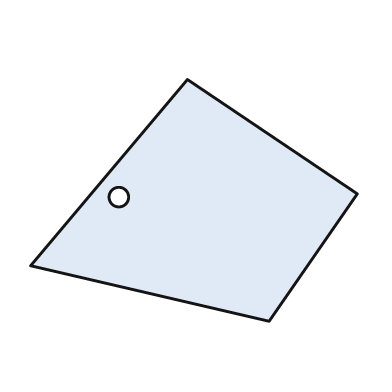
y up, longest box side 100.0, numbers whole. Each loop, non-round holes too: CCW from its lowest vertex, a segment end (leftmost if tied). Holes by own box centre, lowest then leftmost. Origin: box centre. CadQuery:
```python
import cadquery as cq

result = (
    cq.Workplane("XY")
    .moveTo(23.0, -37.0)
    .lineTo(50.0, 2.0)
    .lineTo(-2.0, 37.0)
    .lineTo(-50.0, -20.0)
    .close()
    .moveTo(-23.0, 1.0)
    .circle(3.0)
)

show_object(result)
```